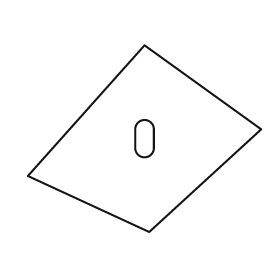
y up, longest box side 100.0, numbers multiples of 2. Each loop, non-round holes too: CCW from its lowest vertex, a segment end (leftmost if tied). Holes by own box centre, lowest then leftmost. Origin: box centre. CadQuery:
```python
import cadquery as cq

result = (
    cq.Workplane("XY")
    .moveTo(2.0, -40.0)
    .lineTo(50.0, 4.0)
    .lineTo(0.0, 40.0)
    .lineTo(-50.0, -16.0)
    .close()
    .moveTo(-4.0, -4.0)
    .threePointArc((0.0, -8.0), (4.0, -4.0))
    .lineTo(4.0, 4.0)
    .threePointArc((0.0, 8.0), (-4.0, 4.0))
    .close()
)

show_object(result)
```